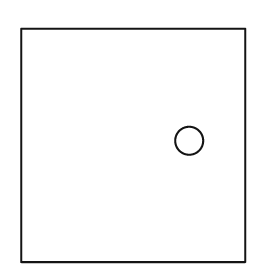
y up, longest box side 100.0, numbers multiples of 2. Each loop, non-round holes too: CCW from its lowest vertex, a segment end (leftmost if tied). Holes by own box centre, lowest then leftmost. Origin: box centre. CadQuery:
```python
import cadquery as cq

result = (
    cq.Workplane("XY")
    .moveTo(-48.0, -50.0)
    .lineTo(48.0, -50.0)
    .lineTo(48.0, 50.0)
    .lineTo(-48.0, 50.0)
    .close()
    .moveTo(24.0, 2.0)
    .circle(6.0)
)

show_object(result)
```